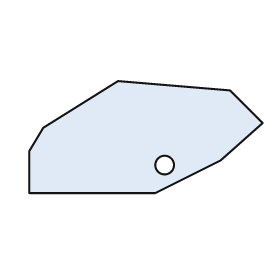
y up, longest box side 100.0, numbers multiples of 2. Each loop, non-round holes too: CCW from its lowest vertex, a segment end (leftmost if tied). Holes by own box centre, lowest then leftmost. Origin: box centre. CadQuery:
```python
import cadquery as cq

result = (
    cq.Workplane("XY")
    .moveTo(-50.0, -24.0)
    .lineTo(4.0, -24.0)
    .lineTo(32.0, -10.0)
    .lineTo(50.0, 6.0)
    .lineTo(36.0, 20.0)
    .lineTo(-12.0, 24.0)
    .lineTo(-44.0, 4.0)
    .lineTo(-50.0, -6.0)
    .close()
    .moveTo(8.0, -12.0)
    .circle(4.0)
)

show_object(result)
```